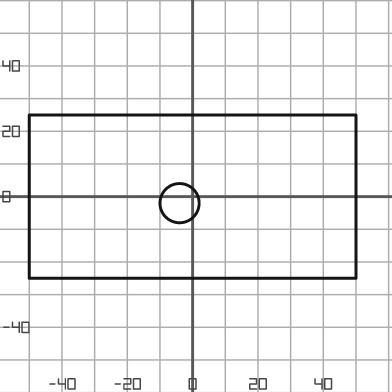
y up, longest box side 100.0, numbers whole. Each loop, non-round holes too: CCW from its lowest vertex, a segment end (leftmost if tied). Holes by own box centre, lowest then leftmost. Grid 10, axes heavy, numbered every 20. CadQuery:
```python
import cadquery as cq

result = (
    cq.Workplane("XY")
    .moveTo(-50.0, -25.0)
    .lineTo(50.0, -25.0)
    .lineTo(50.0, 25.0)
    .lineTo(-50.0, 25.0)
    .close()
    .moveTo(-4.0, -2.0)
    .circle(6.0)
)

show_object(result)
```